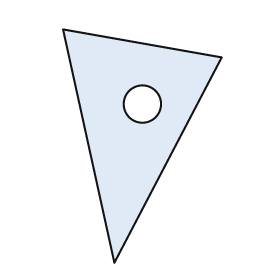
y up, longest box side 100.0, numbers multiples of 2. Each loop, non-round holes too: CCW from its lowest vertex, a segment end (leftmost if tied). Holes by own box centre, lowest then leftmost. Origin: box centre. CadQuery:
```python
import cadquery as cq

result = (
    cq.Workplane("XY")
    .moveTo(-12.0, -50.0)
    .lineTo(34.0, 38.0)
    .lineTo(-34.0, 50.0)
    .close()
    .moveTo(0.0, 18.0)
    .circle(8.0)
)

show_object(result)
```